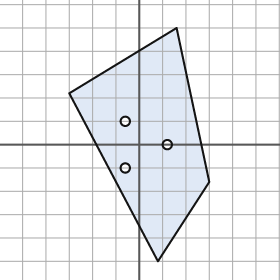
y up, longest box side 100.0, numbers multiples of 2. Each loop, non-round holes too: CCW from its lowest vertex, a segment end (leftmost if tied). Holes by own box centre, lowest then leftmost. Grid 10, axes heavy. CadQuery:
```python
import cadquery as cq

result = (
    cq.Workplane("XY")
    .moveTo(8.0, -50.0)
    .lineTo(30.0, -16.0)
    .lineTo(16.0, 50.0)
    .lineTo(-30.0, 22.0)
    .close()
    .moveTo(-6.0, -10.0)
    .circle(2.0)
    .moveTo(12.0, 0.0)
    .circle(2.0)
    .moveTo(-6.0, 10.0)
    .circle(2.0)
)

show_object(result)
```